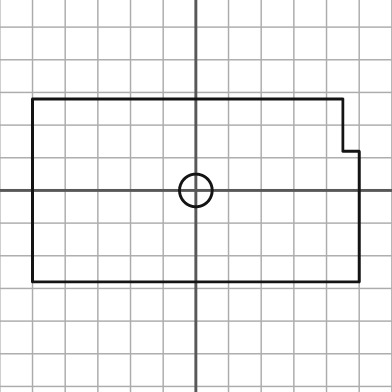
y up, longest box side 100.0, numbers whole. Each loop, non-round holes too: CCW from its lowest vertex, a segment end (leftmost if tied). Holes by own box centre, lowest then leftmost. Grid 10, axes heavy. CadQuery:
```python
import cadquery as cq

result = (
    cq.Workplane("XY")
    .moveTo(-50.0, -28.0)
    .lineTo(50.0, -28.0)
    .lineTo(50.0, 12.0)
    .lineTo(45.0, 12.0)
    .lineTo(45.0, 28.0)
    .lineTo(-50.0, 28.0)
    .close()
    .moveTo(0.0, 0.0)
    .circle(5.0)
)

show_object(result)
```